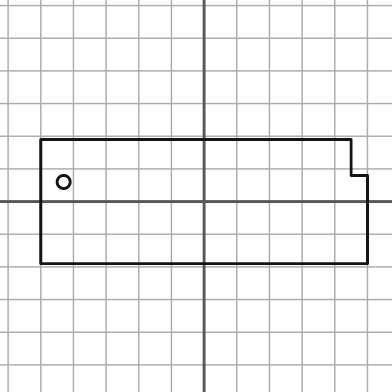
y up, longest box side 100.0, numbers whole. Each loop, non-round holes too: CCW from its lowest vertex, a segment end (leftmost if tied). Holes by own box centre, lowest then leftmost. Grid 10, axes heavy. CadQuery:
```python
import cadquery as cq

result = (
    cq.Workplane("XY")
    .moveTo(-50.0, -19.0)
    .lineTo(50.0, -19.0)
    .lineTo(50.0, 8.0)
    .lineTo(45.0, 8.0)
    .lineTo(45.0, 19.0)
    .lineTo(-50.0, 19.0)
    .close()
    .moveTo(-43.0, 6.0)
    .circle(2.0)
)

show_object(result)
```